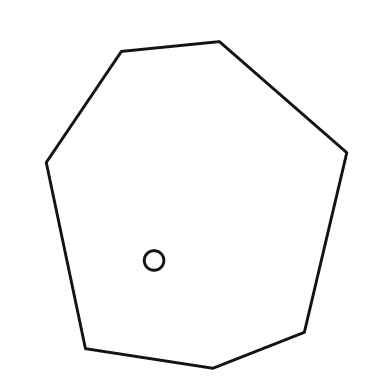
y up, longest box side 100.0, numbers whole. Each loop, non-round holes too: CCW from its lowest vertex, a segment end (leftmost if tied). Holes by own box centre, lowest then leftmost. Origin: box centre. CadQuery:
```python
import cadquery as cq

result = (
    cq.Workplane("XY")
    .moveTo(5.0, -50.0)
    .lineTo(33.0, -39.0)
    .lineTo(46.0, 16.0)
    .lineTo(7.0, 50.0)
    .lineTo(-23.0, 47.0)
    .lineTo(-46.0, 13.0)
    .lineTo(-34.0, -44.0)
    .close()
    .moveTo(-13.0, -17.0)
    .circle(3.0)
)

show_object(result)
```